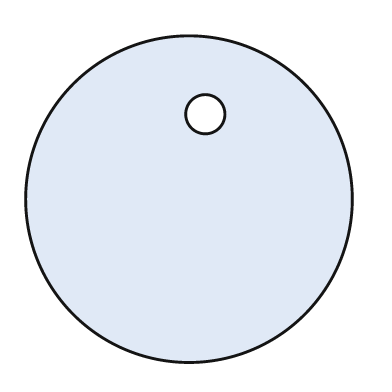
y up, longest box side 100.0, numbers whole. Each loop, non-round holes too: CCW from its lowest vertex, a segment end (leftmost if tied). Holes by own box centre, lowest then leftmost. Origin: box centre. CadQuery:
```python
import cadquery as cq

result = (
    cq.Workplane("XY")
    .moveTo(0.0, 0.0)
    .circle(50.0)
    .moveTo(5.0, 26.0)
    .circle(6.0)
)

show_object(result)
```